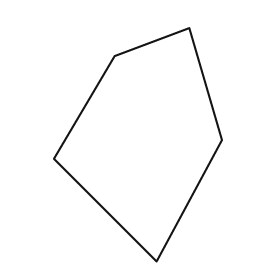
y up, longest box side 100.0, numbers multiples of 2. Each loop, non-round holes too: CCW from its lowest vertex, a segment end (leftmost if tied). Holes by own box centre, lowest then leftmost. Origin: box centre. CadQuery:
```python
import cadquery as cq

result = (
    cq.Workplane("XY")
    .moveTo(8.0, -50.0)
    .lineTo(36.0, 2.0)
    .lineTo(22.0, 50.0)
    .lineTo(-10.0, 38.0)
    .lineTo(-36.0, -6.0)
    .close()
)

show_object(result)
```